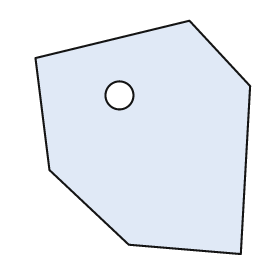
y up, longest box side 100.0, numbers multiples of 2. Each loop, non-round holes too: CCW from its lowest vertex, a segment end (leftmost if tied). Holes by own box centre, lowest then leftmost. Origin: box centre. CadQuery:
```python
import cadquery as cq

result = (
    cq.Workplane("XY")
    .moveTo(42.0, -50.0)
    .lineTo(46.0, 22.0)
    .lineTo(20.0, 50.0)
    .lineTo(-46.0, 34.0)
    .lineTo(-40.0, -14.0)
    .lineTo(-6.0, -46.0)
    .close()
    .moveTo(-10.0, 18.0)
    .circle(6.0)
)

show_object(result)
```